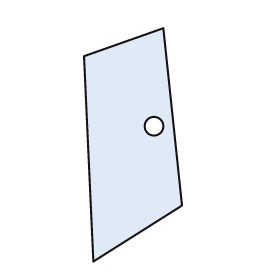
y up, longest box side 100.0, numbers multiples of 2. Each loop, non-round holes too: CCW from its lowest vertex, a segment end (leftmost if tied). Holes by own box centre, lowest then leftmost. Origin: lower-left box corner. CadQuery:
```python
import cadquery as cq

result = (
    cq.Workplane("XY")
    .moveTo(4.0, 0.0)
    .lineTo(42.0, 24.0)
    .lineTo(34.0, 100.0)
    .lineTo(0.0, 88.0)
    .close()
    .moveTo(30.0, 58.0)
    .circle(4.0)
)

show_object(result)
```